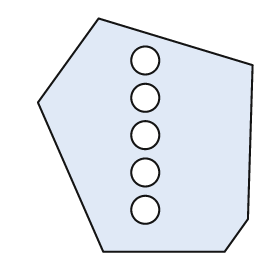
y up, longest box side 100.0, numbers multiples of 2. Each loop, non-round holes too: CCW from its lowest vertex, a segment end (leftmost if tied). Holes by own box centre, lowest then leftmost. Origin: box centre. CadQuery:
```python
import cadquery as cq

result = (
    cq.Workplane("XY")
    .moveTo(-18.0, -50.0)
    .lineTo(34.0, -50.0)
    .lineTo(44.0, -36.0)
    .lineTo(46.0, 30.0)
    .lineTo(-20.0, 50.0)
    .lineTo(-46.0, 14.0)
    .close()
    .moveTo(0.0, -32.0)
    .circle(6.0)
    .moveTo(0.0, -16.0)
    .circle(6.0)
    .moveTo(0.0, 0.0)
    .circle(6.0)
    .moveTo(0.0, 16.0)
    .circle(6.0)
    .moveTo(0.0, 32.0)
    .circle(6.0)
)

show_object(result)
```